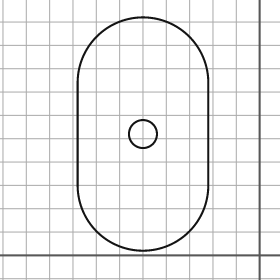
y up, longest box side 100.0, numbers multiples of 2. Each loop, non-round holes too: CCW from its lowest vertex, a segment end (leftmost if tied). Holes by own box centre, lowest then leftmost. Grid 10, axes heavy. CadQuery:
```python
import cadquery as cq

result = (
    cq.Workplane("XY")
    .moveTo(-78.0, 30.0)
    .threePointArc((-50.0, 2.0), (-22.0, 30.0))
    .lineTo(-22.0, 74.0)
    .threePointArc((-50.0, 102.0), (-78.0, 74.0))
    .close()
    .moveTo(-50.0, 52.0)
    .circle(6.0)
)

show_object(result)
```